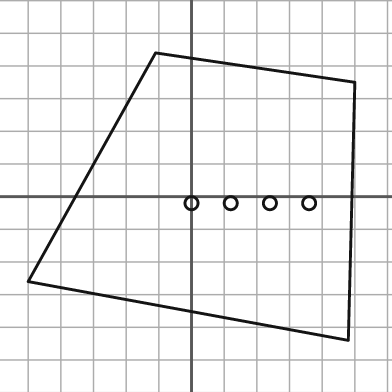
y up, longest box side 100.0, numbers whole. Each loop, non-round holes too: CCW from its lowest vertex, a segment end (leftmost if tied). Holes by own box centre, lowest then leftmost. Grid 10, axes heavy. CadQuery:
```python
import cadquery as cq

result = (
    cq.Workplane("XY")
    .moveTo(48.0, -44.0)
    .lineTo(50.0, 35.0)
    .lineTo(-11.0, 44.0)
    .lineTo(-50.0, -26.0)
    .close()
    .moveTo(0.0, -2.0)
    .circle(2.0)
    .moveTo(12.0, -2.0)
    .circle(2.0)
    .moveTo(24.0, -2.0)
    .circle(2.0)
    .moveTo(36.0, -2.0)
    .circle(2.0)
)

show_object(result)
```